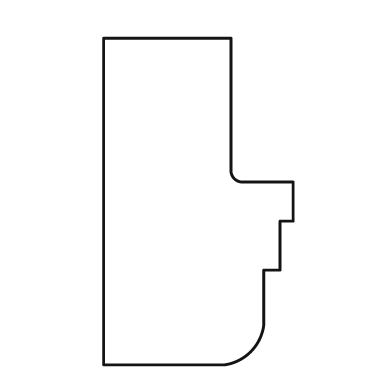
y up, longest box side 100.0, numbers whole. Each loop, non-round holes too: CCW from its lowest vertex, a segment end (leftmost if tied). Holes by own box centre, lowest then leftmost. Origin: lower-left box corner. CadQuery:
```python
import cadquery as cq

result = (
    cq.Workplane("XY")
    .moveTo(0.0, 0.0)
    .lineTo(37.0, 0.0)
    .threePointArc((45.0, 4.0), (49.0, 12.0))
    .lineTo(49.0, 29.0)
    .lineTo(54.0, 29.0)
    .lineTo(54.0, 44.0)
    .lineTo(58.0, 44.0)
    .lineTo(58.0, 56.0)
    .lineTo(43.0, 56.0)
    .threePointArc((40.0, 57.0), (39.0, 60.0))
    .lineTo(39.0, 100.0)
    .lineTo(0.0, 100.0)
    .close()
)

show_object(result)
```